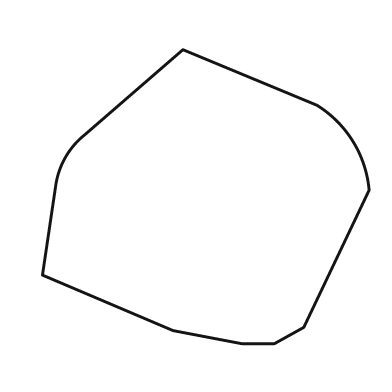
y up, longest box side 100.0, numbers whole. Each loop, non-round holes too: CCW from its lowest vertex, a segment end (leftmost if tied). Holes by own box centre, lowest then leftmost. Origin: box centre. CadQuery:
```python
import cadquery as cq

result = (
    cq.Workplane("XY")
    .moveTo(11.0, -45.0)
    .lineTo(21.0, -45.0)
    .lineTo(30.0, -40.0)
    .lineTo(50.0, 2.0)
    .threePointArc((45.0, 17.0), (34.0, 28.0))
    .lineTo(-7.0, 45.0)
    .lineTo(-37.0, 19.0)
    .threePointArc((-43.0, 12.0), (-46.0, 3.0))
    .lineTo(-50.0, -24.0)
    .lineTo(-10.0, -41.0)
    .close()
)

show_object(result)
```